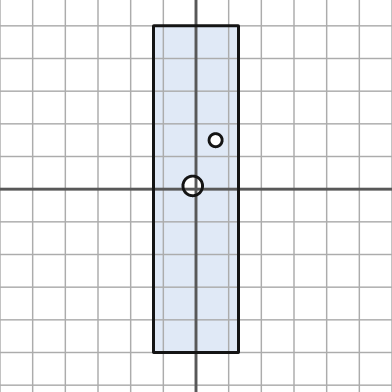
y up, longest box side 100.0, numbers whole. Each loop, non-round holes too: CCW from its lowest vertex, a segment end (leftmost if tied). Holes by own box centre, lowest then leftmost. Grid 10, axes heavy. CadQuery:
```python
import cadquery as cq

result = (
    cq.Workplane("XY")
    .moveTo(-13.0, -50.0)
    .lineTo(13.0, -50.0)
    .lineTo(13.0, 50.0)
    .lineTo(-13.0, 50.0)
    .close()
    .moveTo(-1.0, 1.0)
    .circle(3.0)
    .moveTo(6.0, 15.0)
    .circle(2.0)
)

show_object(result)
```